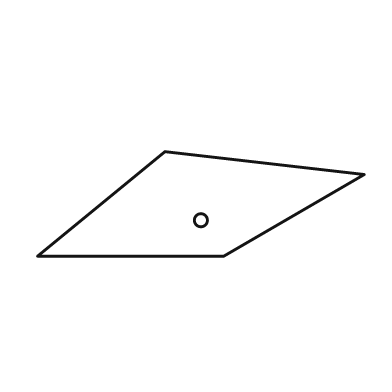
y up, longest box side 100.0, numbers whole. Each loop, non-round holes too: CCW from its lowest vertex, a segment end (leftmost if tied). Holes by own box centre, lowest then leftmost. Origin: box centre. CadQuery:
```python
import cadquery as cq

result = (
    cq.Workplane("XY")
    .moveTo(-50.0, -16.0)
    .lineTo(7.0, -16.0)
    .lineTo(50.0, 9.0)
    .lineTo(-11.0, 16.0)
    .close()
    .moveTo(0.0, -5.0)
    .circle(2.0)
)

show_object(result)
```